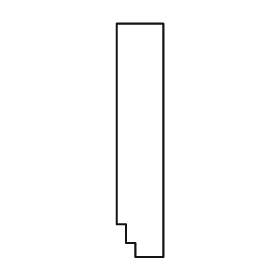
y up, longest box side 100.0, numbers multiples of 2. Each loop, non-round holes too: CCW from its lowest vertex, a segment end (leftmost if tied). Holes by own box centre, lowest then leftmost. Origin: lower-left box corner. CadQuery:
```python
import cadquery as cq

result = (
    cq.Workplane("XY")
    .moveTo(8.0, 0.0)
    .lineTo(20.0, 0.0)
    .lineTo(20.0, 100.0)
    .lineTo(0.0, 100.0)
    .lineTo(0.0, 14.0)
    .lineTo(4.0, 14.0)
    .lineTo(4.0, 6.0)
    .lineTo(8.0, 6.0)
    .close()
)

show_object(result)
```